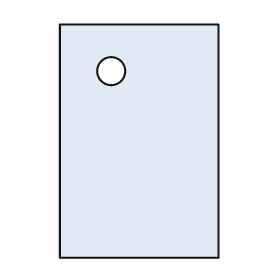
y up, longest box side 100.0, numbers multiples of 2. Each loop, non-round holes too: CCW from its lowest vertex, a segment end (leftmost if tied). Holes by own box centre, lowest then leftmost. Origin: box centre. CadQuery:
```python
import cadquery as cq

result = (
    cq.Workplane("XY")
    .moveTo(-34.0, -50.0)
    .lineTo(34.0, -50.0)
    .lineTo(34.0, 50.0)
    .lineTo(-34.0, 50.0)
    .close()
    .moveTo(-12.0, 30.0)
    .circle(6.0)
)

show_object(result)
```